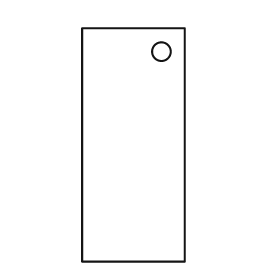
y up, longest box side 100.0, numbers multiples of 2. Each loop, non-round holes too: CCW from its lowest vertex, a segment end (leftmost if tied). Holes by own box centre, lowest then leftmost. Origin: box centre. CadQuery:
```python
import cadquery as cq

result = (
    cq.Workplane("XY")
    .moveTo(-22.0, -50.0)
    .lineTo(22.0, -50.0)
    .lineTo(22.0, 50.0)
    .lineTo(-22.0, 50.0)
    .close()
    .moveTo(12.0, 40.0)
    .circle(4.0)
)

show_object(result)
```